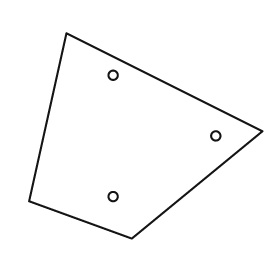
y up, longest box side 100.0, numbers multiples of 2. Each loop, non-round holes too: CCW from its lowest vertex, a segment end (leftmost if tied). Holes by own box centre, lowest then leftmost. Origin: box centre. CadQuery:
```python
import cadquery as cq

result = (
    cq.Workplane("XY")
    .moveTo(-6.0, -44.0)
    .lineTo(50.0, 2.0)
    .lineTo(-34.0, 44.0)
    .lineTo(-50.0, -28.0)
    .close()
    .moveTo(-14.0, -26.0)
    .circle(2.0)
    .moveTo(30.0, 0.0)
    .circle(2.0)
    .moveTo(-14.0, 26.0)
    .circle(2.0)
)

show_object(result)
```